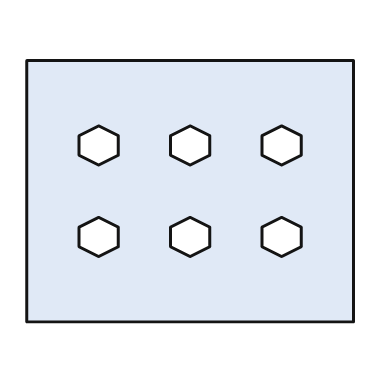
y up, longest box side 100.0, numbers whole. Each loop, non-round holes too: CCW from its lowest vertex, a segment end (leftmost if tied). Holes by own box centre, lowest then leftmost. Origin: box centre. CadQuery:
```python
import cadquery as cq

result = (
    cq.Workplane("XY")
    .moveTo(-50.0, -40.0)
    .lineTo(50.0, -40.0)
    .lineTo(50.0, 40.0)
    .lineTo(-50.0, 40.0)
    .close()
    .moveTo(-28.0, -20.0)
    .lineTo(-22.0, -17.0)
    .lineTo(-22.0, -11.0)
    .lineTo(-28.0, -8.0)
    .lineTo(-34.0, -11.0)
    .lineTo(-34.0, -17.0)
    .close()
    .moveTo(0.0, -20.0)
    .lineTo(6.0, -17.0)
    .lineTo(6.0, -11.0)
    .lineTo(0.0, -8.0)
    .lineTo(-6.0, -11.0)
    .lineTo(-6.0, -17.0)
    .close()
    .moveTo(28.0, -20.0)
    .lineTo(34.0, -17.0)
    .lineTo(34.0, -11.0)
    .lineTo(28.0, -8.0)
    .lineTo(22.0, -11.0)
    .lineTo(22.0, -17.0)
    .close()
    .moveTo(-28.0, 8.0)
    .lineTo(-22.0, 11.0)
    .lineTo(-22.0, 17.0)
    .lineTo(-28.0, 20.0)
    .lineTo(-34.0, 17.0)
    .lineTo(-34.0, 11.0)
    .close()
    .moveTo(0.0, 8.0)
    .lineTo(6.0, 11.0)
    .lineTo(6.0, 17.0)
    .lineTo(0.0, 20.0)
    .lineTo(-6.0, 17.0)
    .lineTo(-6.0, 11.0)
    .close()
    .moveTo(28.0, 8.0)
    .lineTo(34.0, 11.0)
    .lineTo(34.0, 17.0)
    .lineTo(28.0, 20.0)
    .lineTo(22.0, 17.0)
    .lineTo(22.0, 11.0)
    .close()
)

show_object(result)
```